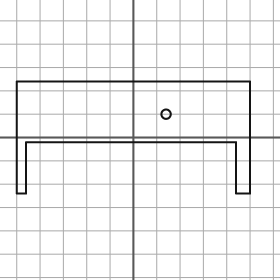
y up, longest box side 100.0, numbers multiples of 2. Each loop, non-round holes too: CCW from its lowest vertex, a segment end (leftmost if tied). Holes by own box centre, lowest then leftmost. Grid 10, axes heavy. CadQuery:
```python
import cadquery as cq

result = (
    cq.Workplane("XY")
    .moveTo(-50.0, -24.0)
    .lineTo(-46.0, -24.0)
    .lineTo(-46.0, -2.0)
    .lineTo(44.0, -2.0)
    .lineTo(44.0, -24.0)
    .lineTo(50.0, -24.0)
    .lineTo(50.0, 24.0)
    .lineTo(-50.0, 24.0)
    .close()
    .moveTo(14.0, 10.0)
    .circle(2.0)
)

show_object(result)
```